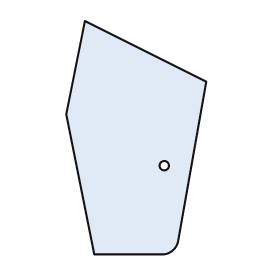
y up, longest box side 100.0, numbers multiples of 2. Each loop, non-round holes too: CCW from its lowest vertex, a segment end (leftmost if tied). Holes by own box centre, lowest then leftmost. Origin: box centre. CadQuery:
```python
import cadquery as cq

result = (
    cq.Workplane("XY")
    .moveTo(-18.0, -50.0)
    .lineTo(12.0, -50.0)
    .threePointArc((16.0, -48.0), (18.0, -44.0))
    .lineTo(30.0, 24.0)
    .lineTo(-22.0, 50.0)
    .lineTo(-30.0, 10.0)
    .close()
    .moveTo(12.0, -12.0)
    .circle(2.0)
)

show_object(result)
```